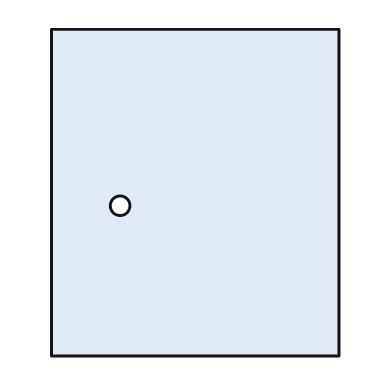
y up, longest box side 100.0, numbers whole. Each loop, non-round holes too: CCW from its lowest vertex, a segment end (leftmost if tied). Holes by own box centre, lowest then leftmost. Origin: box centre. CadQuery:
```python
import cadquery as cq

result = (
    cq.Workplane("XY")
    .moveTo(-44.0, -50.0)
    .lineTo(44.0, -50.0)
    .lineTo(44.0, 50.0)
    .lineTo(-44.0, 50.0)
    .close()
    .moveTo(-23.0, -4.0)
    .circle(3.0)
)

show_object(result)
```